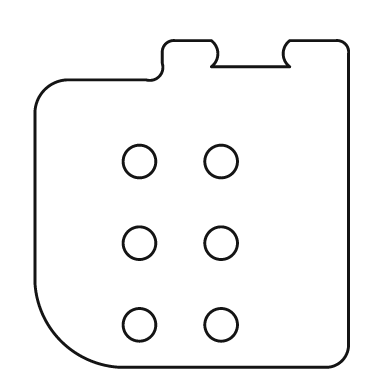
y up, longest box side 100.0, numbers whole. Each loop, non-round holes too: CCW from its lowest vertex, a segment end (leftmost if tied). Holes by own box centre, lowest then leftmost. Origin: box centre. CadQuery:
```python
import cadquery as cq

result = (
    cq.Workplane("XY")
    .moveTo(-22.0, -50.0)
    .lineTo(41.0, -50.0)
    .threePointArc((46.0, -48.0), (48.0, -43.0))
    .lineTo(48.0, 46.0)
    .threePointArc((47.0, 49.0), (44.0, 50.0))
    .lineTo(30.0, 50.0)
    .threePointArc((28.0, 46.0), (30.0, 42.0))
    .lineTo(6.0, 42.0)
    .threePointArc((8.0, 46.0), (6.0, 50.0))
    .lineTo(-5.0, 50.0)
    .threePointArc((-8.0, 49.0), (-9.0, 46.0))
    .lineTo(-9.0, 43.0)
    .threePointArc((-10.0, 39.0), (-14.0, 38.0))
    .lineTo(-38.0, 38.0)
    .threePointArc((-45.0, 35.0), (-48.0, 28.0))
    .lineTo(-48.0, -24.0)
    .threePointArc((-40.0, -42.0), (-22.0, -50.0))
    .close()
    .moveTo(-16.0, -37.0)
    .circle(5.0)
    .moveTo(9.0, -37.0)
    .circle(5.0)
    .moveTo(-16.0, -12.0)
    .circle(5.0)
    .moveTo(9.0, -12.0)
    .circle(5.0)
    .moveTo(-16.0, 13.0)
    .circle(5.0)
    .moveTo(9.0, 13.0)
    .circle(5.0)
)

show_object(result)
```